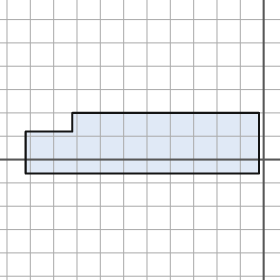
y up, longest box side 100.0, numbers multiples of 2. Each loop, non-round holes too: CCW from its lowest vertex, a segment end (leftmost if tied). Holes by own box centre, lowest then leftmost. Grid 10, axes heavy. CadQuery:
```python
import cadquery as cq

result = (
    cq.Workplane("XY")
    .moveTo(-102.0, -6.0)
    .lineTo(-2.0, -6.0)
    .lineTo(-2.0, 20.0)
    .lineTo(-82.0, 20.0)
    .lineTo(-82.0, 12.0)
    .lineTo(-102.0, 12.0)
    .close()
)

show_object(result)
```